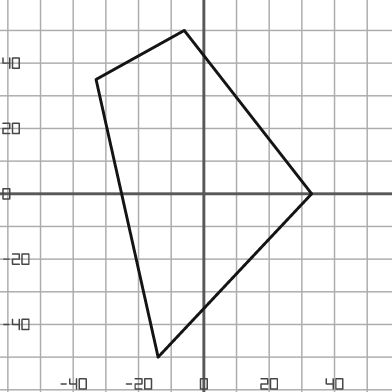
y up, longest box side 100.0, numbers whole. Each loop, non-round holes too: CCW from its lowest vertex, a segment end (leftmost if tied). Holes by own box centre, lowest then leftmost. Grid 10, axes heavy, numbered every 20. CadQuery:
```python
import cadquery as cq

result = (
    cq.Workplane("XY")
    .moveTo(-14.0, -50.0)
    .lineTo(33.0, 0.0)
    .lineTo(-6.0, 50.0)
    .lineTo(-33.0, 35.0)
    .close()
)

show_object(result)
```